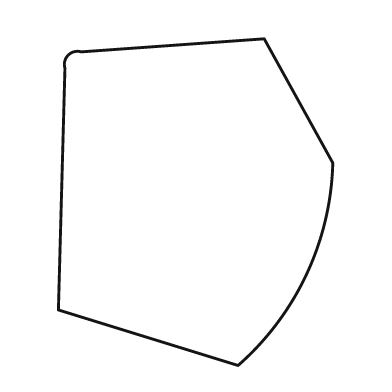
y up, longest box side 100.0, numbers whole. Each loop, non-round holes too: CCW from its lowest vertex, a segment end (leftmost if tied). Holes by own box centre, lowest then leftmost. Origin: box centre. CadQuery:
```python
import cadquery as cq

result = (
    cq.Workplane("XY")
    .moveTo(13.0, -50.0)
    .threePointArc((34.0, -22.0), (42.0, 12.0))
    .lineTo(21.0, 50.0)
    .lineTo(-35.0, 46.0)
    .threePointArc((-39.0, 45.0), (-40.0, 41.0))
    .lineTo(-42.0, -33.0)
    .close()
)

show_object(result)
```